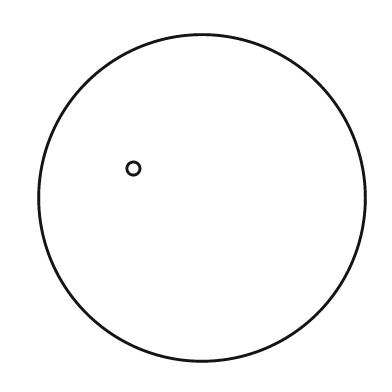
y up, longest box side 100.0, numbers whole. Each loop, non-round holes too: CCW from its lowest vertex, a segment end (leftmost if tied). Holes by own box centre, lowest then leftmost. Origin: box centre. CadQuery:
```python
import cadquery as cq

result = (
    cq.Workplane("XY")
    .moveTo(0.0, 0.0)
    .circle(50.0)
    .moveTo(-21.0, 9.0)
    .circle(2.0)
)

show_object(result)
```